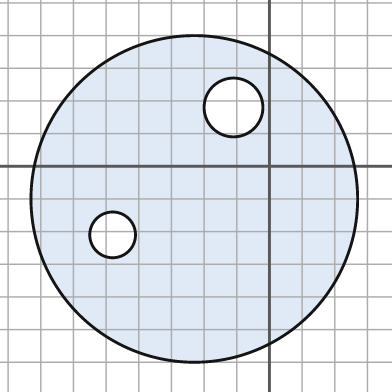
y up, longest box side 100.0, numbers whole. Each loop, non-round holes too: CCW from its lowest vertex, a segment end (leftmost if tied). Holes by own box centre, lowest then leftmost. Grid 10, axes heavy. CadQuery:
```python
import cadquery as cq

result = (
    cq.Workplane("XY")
    .moveTo(-23.0, -10.0)
    .circle(50.0)
    .moveTo(-48.0, -21.0)
    .circle(7.0)
    .moveTo(-11.0, 18.0)
    .circle(9.0)
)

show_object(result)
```